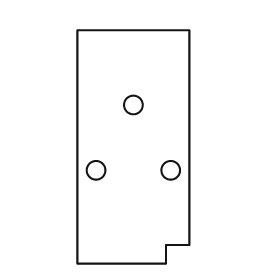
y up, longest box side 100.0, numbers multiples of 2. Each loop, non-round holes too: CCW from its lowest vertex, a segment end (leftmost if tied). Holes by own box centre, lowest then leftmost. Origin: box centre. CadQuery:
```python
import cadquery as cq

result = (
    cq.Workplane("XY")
    .moveTo(-24.0, -50.0)
    .lineTo(14.0, -50.0)
    .lineTo(14.0, -42.0)
    .lineTo(24.0, -42.0)
    .lineTo(24.0, 50.0)
    .lineTo(-24.0, 50.0)
    .close()
    .moveTo(-16.0, -10.0)
    .circle(4.0)
    .moveTo(16.0, -10.0)
    .circle(4.0)
    .moveTo(0.0, 18.0)
    .circle(4.0)
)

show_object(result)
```